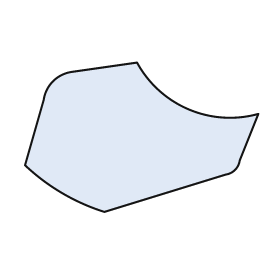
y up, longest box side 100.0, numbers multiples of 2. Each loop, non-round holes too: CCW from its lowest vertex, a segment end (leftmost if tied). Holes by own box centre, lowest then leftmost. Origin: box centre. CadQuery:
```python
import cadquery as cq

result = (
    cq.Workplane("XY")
    .moveTo(-16.0, -32.0)
    .lineTo(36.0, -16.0)
    .threePointArc((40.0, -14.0), (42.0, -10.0))
    .lineTo(50.0, 10.0)
    .threePointArc((20.0, 12.0), (-2.0, 32.0))
    .lineTo(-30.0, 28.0)
    .threePointArc((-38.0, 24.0), (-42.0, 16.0))
    .lineTo(-50.0, -12.0)
    .threePointArc((-34.0, -24.0), (-16.0, -32.0))
    .close()
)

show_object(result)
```